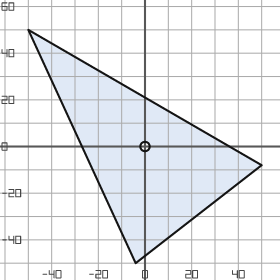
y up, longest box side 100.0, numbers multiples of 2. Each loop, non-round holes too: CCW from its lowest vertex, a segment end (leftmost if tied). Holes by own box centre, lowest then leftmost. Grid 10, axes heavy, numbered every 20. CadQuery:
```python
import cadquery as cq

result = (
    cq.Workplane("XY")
    .moveTo(-4.0, -50.0)
    .lineTo(50.0, -8.0)
    .lineTo(-50.0, 50.0)
    .close()
    .moveTo(0.0, 0.0)
    .circle(2.0)
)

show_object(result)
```